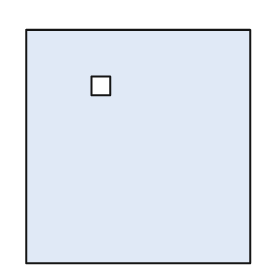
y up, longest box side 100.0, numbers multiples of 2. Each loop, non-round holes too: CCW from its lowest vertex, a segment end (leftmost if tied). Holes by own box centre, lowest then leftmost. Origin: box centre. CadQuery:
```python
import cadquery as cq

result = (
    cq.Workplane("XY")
    .moveTo(-48.0, -50.0)
    .lineTo(48.0, -50.0)
    .lineTo(48.0, 50.0)
    .lineTo(-48.0, 50.0)
    .close()
    .moveTo(-20.0, 22.0)
    .lineTo(-12.0, 22.0)
    .lineTo(-12.0, 30.0)
    .lineTo(-20.0, 30.0)
    .close()
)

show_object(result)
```